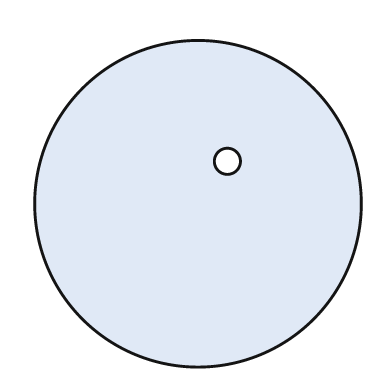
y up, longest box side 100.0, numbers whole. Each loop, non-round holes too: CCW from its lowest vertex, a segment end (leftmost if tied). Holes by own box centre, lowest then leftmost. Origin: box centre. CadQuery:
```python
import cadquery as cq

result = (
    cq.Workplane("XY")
    .moveTo(0.0, 0.0)
    .circle(50.0)
    .moveTo(9.0, 13.0)
    .circle(4.0)
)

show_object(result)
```